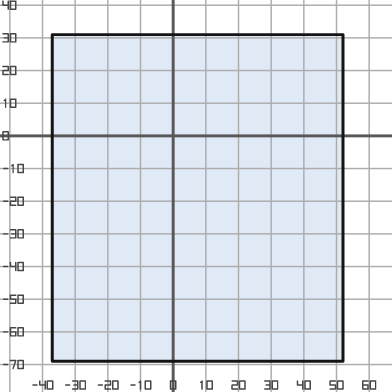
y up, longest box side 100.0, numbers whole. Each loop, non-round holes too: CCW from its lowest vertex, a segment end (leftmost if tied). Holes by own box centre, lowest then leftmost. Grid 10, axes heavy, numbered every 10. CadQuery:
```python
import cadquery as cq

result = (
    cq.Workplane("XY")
    .moveTo(-37.0, -69.0)
    .lineTo(52.0, -69.0)
    .lineTo(52.0, 31.0)
    .lineTo(-37.0, 31.0)
    .close()
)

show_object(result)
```